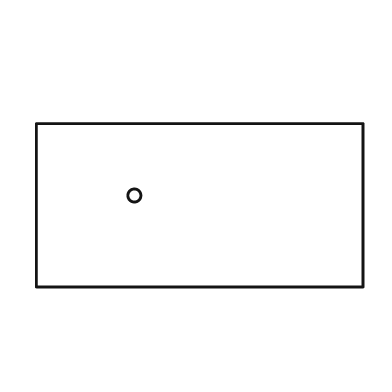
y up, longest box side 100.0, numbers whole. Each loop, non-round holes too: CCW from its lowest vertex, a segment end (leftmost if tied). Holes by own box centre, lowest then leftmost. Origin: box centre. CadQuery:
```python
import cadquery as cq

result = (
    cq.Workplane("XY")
    .moveTo(-50.0, -25.0)
    .lineTo(50.0, -25.0)
    .lineTo(50.0, 25.0)
    .lineTo(-50.0, 25.0)
    .close()
    .moveTo(-20.0, 3.0)
    .circle(2.0)
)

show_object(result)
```